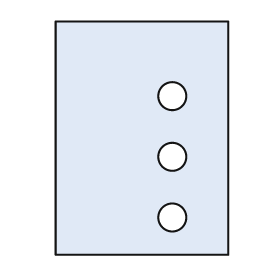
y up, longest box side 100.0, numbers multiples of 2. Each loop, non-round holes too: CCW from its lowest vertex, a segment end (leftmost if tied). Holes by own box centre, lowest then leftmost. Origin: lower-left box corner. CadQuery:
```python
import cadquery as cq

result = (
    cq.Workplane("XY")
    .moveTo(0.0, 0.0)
    .lineTo(74.0, 0.0)
    .lineTo(74.0, 100.0)
    .lineTo(0.0, 100.0)
    .close()
    .moveTo(50.0, 16.0)
    .circle(6.0)
    .moveTo(50.0, 42.0)
    .circle(6.0)
    .moveTo(50.0, 68.0)
    .circle(6.0)
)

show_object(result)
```